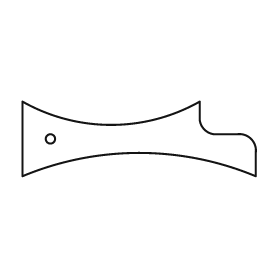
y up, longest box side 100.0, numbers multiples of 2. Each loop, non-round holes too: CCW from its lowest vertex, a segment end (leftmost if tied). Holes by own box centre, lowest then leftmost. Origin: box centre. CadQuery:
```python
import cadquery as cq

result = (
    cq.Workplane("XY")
    .moveTo(-50.0, -16.0)
    .threePointArc((0.0, -6.0), (50.0, -16.0))
    .lineTo(50.0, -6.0)
    .threePointArc((48.0, 0.0), (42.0, 2.0))
    .lineTo(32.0, 2.0)
    .threePointArc((28.0, 4.0), (26.0, 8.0))
    .lineTo(26.0, 16.0)
    .threePointArc((-12.0, 6.0), (-50.0, 16.0))
    .close()
    .moveTo(-38.0, 0.0)
    .circle(2.0)
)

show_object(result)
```